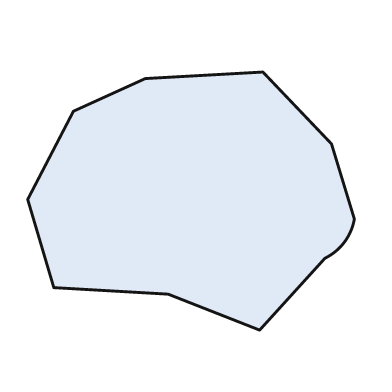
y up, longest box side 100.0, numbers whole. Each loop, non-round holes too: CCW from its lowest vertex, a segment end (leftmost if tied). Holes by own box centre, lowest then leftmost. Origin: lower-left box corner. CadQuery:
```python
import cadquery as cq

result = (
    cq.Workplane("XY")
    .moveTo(71.0, 0.0)
    .lineTo(91.0, 22.0)
    .threePointArc((97.0, 27.0), (100.0, 34.0))
    .lineTo(93.0, 57.0)
    .lineTo(72.0, 79.0)
    .lineTo(36.0, 77.0)
    .lineTo(14.0, 67.0)
    .lineTo(0.0, 40.0)
    .lineTo(8.0, 13.0)
    .lineTo(43.0, 11.0)
    .close()
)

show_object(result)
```